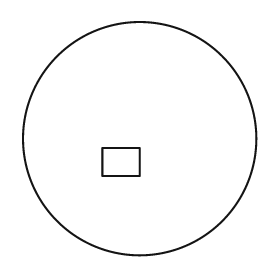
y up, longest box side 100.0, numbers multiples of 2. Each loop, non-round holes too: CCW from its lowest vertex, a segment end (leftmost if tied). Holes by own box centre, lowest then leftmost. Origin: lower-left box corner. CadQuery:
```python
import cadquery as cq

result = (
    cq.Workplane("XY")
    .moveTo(50.0, 50.0)
    .circle(50.0)
    .moveTo(34.0, 34.0)
    .lineTo(50.0, 34.0)
    .lineTo(50.0, 46.0)
    .lineTo(34.0, 46.0)
    .close()
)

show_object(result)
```